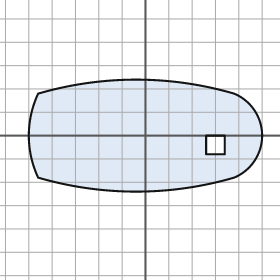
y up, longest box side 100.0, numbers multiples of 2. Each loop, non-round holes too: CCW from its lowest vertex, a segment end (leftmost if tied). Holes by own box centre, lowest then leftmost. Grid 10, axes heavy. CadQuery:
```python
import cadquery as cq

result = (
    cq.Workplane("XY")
    .moveTo(-46.0, -18.0)
    .threePointArc((-4.0, -24.0), (38.0, -18.0))
    .threePointArc((50.0, 0.0), (38.0, 18.0))
    .threePointArc((-4.0, 24.0), (-46.0, 18.0))
    .threePointArc((-50.0, 0.0), (-46.0, -18.0))
    .close()
    .moveTo(26.0, -8.0)
    .lineTo(34.0, -8.0)
    .lineTo(34.0, 0.0)
    .lineTo(26.0, 0.0)
    .close()
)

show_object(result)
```